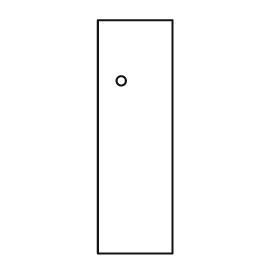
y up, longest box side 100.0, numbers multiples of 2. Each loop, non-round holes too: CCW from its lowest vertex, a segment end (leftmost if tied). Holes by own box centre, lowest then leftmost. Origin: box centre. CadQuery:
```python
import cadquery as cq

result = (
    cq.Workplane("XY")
    .moveTo(-16.0, -50.0)
    .lineTo(16.0, -50.0)
    .lineTo(16.0, 50.0)
    .lineTo(-16.0, 50.0)
    .close()
    .moveTo(-6.0, 24.0)
    .circle(2.0)
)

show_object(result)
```